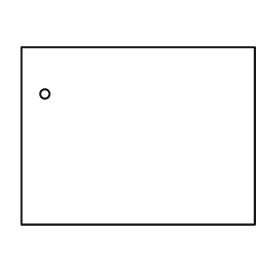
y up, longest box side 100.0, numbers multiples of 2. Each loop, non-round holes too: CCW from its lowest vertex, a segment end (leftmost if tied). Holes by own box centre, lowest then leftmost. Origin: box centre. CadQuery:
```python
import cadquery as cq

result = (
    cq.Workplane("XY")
    .moveTo(-50.0, -38.0)
    .lineTo(50.0, -38.0)
    .lineTo(50.0, 38.0)
    .lineTo(-50.0, 38.0)
    .close()
    .moveTo(-40.0, 18.0)
    .circle(2.0)
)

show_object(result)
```